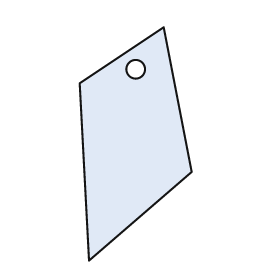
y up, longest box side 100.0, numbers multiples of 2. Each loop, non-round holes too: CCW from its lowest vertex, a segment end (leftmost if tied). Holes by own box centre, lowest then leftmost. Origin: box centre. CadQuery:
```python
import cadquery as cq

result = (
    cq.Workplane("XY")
    .moveTo(-20.0, -50.0)
    .lineTo(24.0, -12.0)
    .lineTo(12.0, 50.0)
    .lineTo(-24.0, 26.0)
    .close()
    .moveTo(0.0, 32.0)
    .circle(4.0)
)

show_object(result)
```